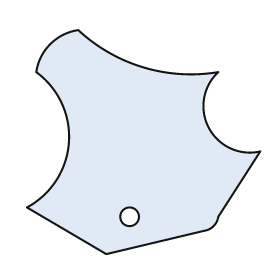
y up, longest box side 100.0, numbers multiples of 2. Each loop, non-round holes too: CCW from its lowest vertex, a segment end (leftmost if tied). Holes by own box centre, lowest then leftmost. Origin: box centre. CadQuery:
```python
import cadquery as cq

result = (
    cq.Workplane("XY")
    .moveTo(-16.0, -48.0)
    .lineTo(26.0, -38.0)
    .threePointArc((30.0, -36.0), (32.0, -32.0))
    .lineTo(50.0, -4.0)
    .threePointArc((28.0, 6.0), (32.0, 30.0))
    .threePointArc((0.0, 32.0), (-28.0, 48.0))
    .threePointArc((-40.0, 42.0), (-46.0, 30.0))
    .threePointArc((-32.0, 0.0), (-50.0, -28.0))
    .close()
    .moveTo(-6.0, -32.0)
    .circle(4.0)
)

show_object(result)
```